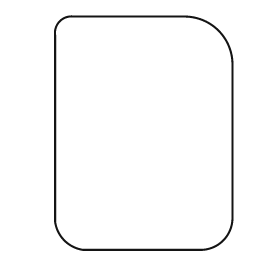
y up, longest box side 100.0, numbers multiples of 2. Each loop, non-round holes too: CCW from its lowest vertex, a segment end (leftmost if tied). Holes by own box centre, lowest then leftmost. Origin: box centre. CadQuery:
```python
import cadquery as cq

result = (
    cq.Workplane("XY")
    .moveTo(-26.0, -50.0)
    .lineTo(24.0, -50.0)
    .threePointArc((34.0, -46.0), (38.0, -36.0))
    .lineTo(38.0, 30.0)
    .threePointArc((32.0, 44.0), (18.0, 50.0))
    .lineTo(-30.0, 50.0)
    .threePointArc((-36.0, 48.0), (-38.0, 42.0))
    .lineTo(-38.0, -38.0)
    .threePointArc((-34.0, -46.0), (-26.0, -50.0))
    .close()
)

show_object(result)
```